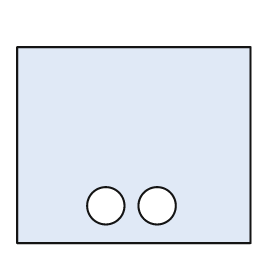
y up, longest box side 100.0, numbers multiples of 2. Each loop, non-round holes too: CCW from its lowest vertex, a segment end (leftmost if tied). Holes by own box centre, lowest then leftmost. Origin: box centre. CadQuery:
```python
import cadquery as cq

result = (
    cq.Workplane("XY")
    .moveTo(-50.0, -42.0)
    .lineTo(50.0, -42.0)
    .lineTo(50.0, 42.0)
    .lineTo(-50.0, 42.0)
    .close()
    .moveTo(-12.0, -26.0)
    .circle(8.0)
    .moveTo(10.0, -26.0)
    .circle(8.0)
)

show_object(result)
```